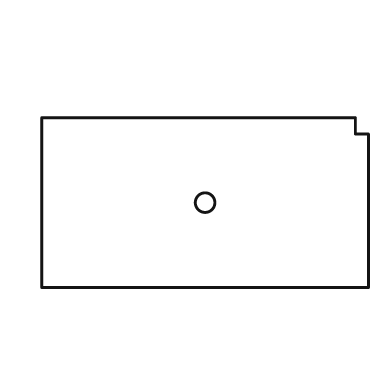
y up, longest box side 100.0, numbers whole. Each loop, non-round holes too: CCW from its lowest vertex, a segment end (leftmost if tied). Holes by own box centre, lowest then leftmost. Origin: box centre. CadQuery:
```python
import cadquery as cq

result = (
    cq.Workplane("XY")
    .moveTo(-50.0, -26.0)
    .lineTo(50.0, -26.0)
    .lineTo(50.0, 21.0)
    .lineTo(46.0, 21.0)
    .lineTo(46.0, 26.0)
    .lineTo(-50.0, 26.0)
    .close()
    .moveTo(0.0, 0.0)
    .circle(3.0)
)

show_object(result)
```